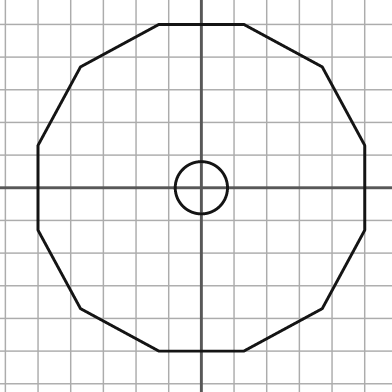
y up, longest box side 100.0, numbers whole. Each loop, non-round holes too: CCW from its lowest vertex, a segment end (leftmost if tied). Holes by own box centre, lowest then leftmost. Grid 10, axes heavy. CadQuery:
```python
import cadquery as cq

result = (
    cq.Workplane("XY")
    .moveTo(-13.0, -50.0)
    .lineTo(13.0, -50.0)
    .lineTo(37.0, -37.0)
    .lineTo(50.0, -13.0)
    .lineTo(50.0, 13.0)
    .lineTo(37.0, 37.0)
    .lineTo(13.0, 50.0)
    .lineTo(-13.0, 50.0)
    .lineTo(-37.0, 37.0)
    .lineTo(-50.0, 13.0)
    .lineTo(-50.0, -13.0)
    .lineTo(-37.0, -37.0)
    .close()
    .moveTo(0.0, 0.0)
    .circle(8.0)
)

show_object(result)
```